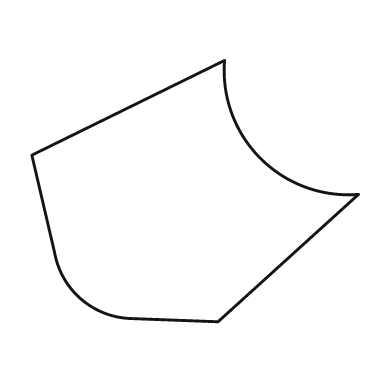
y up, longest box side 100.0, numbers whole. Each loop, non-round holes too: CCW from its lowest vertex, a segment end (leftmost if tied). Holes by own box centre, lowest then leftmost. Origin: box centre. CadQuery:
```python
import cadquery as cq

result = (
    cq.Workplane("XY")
    .moveTo(7.0, -40.0)
    .lineTo(50.0, -1.0)
    .threePointArc((20.0, 10.0), (9.0, 40.0))
    .lineTo(-50.0, 11.0)
    .lineTo(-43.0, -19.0)
    .threePointArc((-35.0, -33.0), (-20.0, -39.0))
    .close()
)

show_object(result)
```